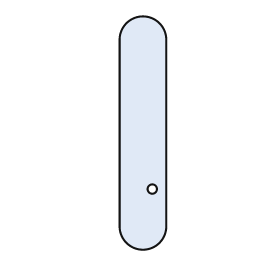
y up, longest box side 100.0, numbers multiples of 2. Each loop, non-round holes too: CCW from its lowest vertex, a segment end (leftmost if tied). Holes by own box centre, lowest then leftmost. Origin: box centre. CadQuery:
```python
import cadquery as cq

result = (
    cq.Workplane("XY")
    .moveTo(-10.0, -40.0)
    .threePointArc((0.0, -50.0), (10.0, -40.0))
    .lineTo(10.0, 40.0)
    .threePointArc((0.0, 50.0), (-10.0, 40.0))
    .close()
    .moveTo(4.0, -24.0)
    .circle(2.0)
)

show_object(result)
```